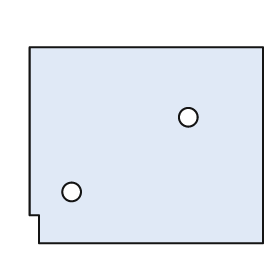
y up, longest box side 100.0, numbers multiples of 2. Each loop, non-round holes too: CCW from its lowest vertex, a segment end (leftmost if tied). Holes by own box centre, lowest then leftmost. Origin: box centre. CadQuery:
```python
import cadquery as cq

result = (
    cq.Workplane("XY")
    .moveTo(-46.0, -42.0)
    .lineTo(50.0, -42.0)
    .lineTo(50.0, 42.0)
    .lineTo(-50.0, 42.0)
    .lineTo(-50.0, -30.0)
    .lineTo(-46.0, -30.0)
    .close()
    .moveTo(-32.0, -20.0)
    .circle(4.0)
    .moveTo(18.0, 12.0)
    .circle(4.0)
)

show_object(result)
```